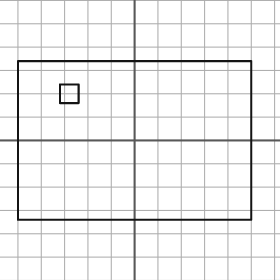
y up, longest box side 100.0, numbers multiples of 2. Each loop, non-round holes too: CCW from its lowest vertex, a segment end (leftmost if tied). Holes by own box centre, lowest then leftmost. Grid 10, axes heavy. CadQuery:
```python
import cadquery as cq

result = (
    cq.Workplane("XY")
    .moveTo(-50.0, -34.0)
    .lineTo(50.0, -34.0)
    .lineTo(50.0, 34.0)
    .lineTo(-50.0, 34.0)
    .close()
    .moveTo(-32.0, 16.0)
    .lineTo(-24.0, 16.0)
    .lineTo(-24.0, 24.0)
    .lineTo(-32.0, 24.0)
    .close()
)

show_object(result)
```